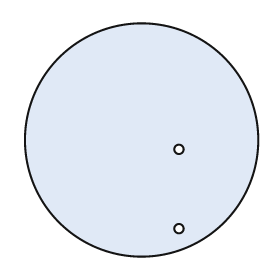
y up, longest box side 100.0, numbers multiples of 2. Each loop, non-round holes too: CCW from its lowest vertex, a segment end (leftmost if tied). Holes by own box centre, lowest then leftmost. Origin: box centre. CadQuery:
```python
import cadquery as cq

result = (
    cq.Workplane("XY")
    .moveTo(0.0, 0.0)
    .circle(50.0)
    .moveTo(16.0, -38.0)
    .circle(2.0)
    .moveTo(16.0, -4.0)
    .circle(2.0)
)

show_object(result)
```